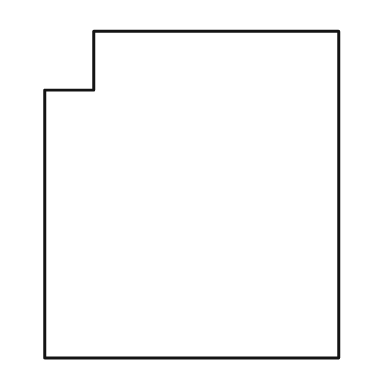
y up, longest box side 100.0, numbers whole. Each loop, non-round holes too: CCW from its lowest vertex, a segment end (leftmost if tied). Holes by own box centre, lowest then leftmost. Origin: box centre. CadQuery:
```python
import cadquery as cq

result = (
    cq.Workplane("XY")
    .moveTo(-45.0, -50.0)
    .lineTo(45.0, -50.0)
    .lineTo(45.0, 50.0)
    .lineTo(-30.0, 50.0)
    .lineTo(-30.0, 32.0)
    .lineTo(-45.0, 32.0)
    .close()
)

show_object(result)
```